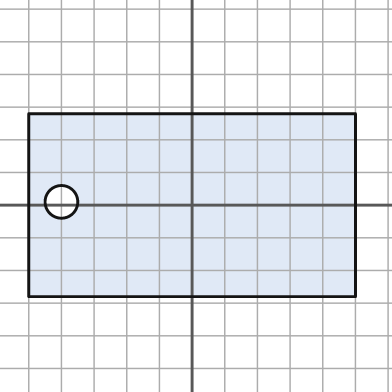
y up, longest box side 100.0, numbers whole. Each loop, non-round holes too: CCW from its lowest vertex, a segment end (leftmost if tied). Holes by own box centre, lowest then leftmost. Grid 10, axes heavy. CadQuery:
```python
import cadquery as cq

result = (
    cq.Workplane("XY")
    .moveTo(-50.0, -28.0)
    .lineTo(50.0, -28.0)
    .lineTo(50.0, 28.0)
    .lineTo(-50.0, 28.0)
    .close()
    .moveTo(-40.0, 1.0)
    .circle(5.0)
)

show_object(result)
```